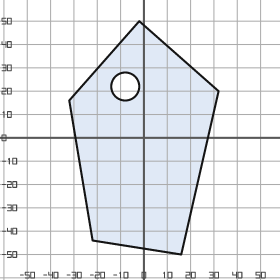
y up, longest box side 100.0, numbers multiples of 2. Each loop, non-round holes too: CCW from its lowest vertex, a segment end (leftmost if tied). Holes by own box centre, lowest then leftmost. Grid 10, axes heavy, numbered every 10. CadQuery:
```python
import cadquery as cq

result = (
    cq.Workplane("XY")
    .moveTo(16.0, -50.0)
    .lineTo(32.0, 20.0)
    .lineTo(-2.0, 50.0)
    .lineTo(-32.0, 16.0)
    .lineTo(-22.0, -44.0)
    .close()
    .moveTo(-8.0, 22.0)
    .circle(6.0)
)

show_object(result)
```